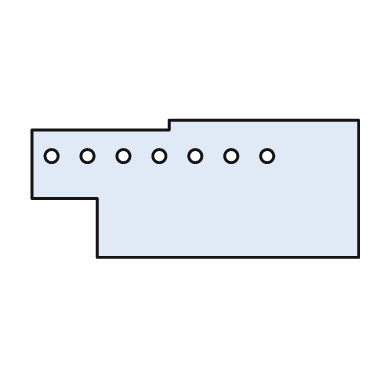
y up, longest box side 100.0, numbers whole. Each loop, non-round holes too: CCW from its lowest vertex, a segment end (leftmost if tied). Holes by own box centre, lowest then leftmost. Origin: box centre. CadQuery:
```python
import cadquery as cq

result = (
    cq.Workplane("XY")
    .moveTo(-30.0, -21.0)
    .lineTo(50.0, -21.0)
    .lineTo(50.0, 21.0)
    .lineTo(-8.0, 21.0)
    .lineTo(-8.0, 18.0)
    .lineTo(-50.0, 18.0)
    .lineTo(-50.0, -3.0)
    .lineTo(-30.0, -3.0)
    .close()
    .moveTo(-44.0, 10.0)
    .circle(2.0)
    .moveTo(-33.0, 10.0)
    .circle(2.0)
    .moveTo(-22.0, 10.0)
    .circle(2.0)
    .moveTo(-11.0, 10.0)
    .circle(2.0)
    .moveTo(0.0, 10.0)
    .circle(2.0)
    .moveTo(11.0, 10.0)
    .circle(2.0)
    .moveTo(22.0, 10.0)
    .circle(2.0)
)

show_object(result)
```